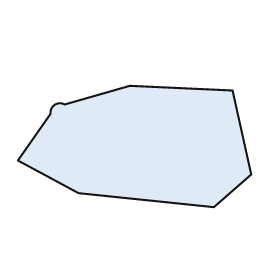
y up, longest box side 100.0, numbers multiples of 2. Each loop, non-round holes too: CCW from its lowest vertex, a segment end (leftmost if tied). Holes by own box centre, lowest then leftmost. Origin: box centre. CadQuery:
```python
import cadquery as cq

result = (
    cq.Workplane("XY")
    .moveTo(34.0, -26.0)
    .lineTo(50.0, -12.0)
    .lineTo(42.0, 24.0)
    .lineTo(-2.0, 26.0)
    .lineTo(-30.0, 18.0)
    .threePointArc((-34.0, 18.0), (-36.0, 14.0))
    .lineTo(-50.0, -6.0)
    .lineTo(-24.0, -20.0)
    .close()
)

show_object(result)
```